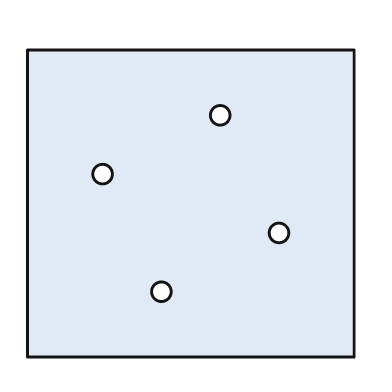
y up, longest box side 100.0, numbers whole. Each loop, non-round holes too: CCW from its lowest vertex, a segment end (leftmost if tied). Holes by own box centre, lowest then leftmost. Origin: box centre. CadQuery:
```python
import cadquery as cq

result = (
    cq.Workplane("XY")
    .moveTo(-50.0, -47.0)
    .lineTo(50.0, -47.0)
    .lineTo(50.0, 47.0)
    .lineTo(-50.0, 47.0)
    .close()
    .moveTo(-9.0, -27.0)
    .circle(3.0)
    .moveTo(27.0, -9.0)
    .circle(3.0)
    .moveTo(-27.0, 9.0)
    .circle(3.0)
    .moveTo(9.0, 27.0)
    .circle(3.0)
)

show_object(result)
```